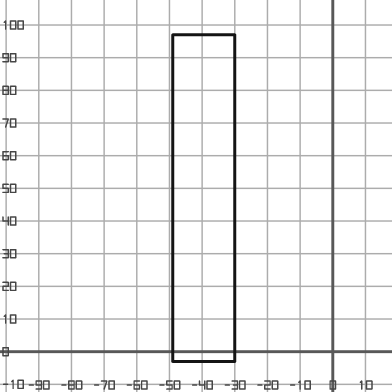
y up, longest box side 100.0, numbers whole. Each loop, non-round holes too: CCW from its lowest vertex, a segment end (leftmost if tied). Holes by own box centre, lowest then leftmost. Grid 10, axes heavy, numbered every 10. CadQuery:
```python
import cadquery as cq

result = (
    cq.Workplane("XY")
    .moveTo(-49.0, -3.0)
    .lineTo(-30.0, -3.0)
    .lineTo(-30.0, 97.0)
    .lineTo(-49.0, 97.0)
    .close()
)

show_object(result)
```